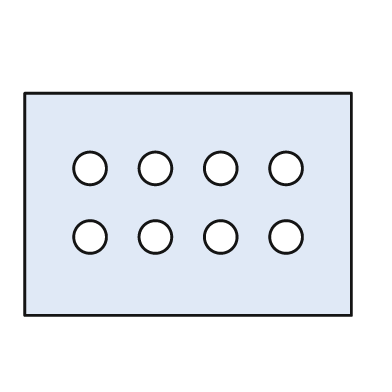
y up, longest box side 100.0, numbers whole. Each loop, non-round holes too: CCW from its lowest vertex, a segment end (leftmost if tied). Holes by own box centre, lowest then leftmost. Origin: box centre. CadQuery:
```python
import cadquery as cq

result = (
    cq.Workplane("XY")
    .moveTo(-50.0, -34.0)
    .lineTo(50.0, -34.0)
    .lineTo(50.0, 34.0)
    .lineTo(-50.0, 34.0)
    .close()
    .moveTo(-30.0, -10.0)
    .circle(5.0)
    .moveTo(-10.0, -10.0)
    .circle(5.0)
    .moveTo(10.0, -10.0)
    .circle(5.0)
    .moveTo(30.0, -10.0)
    .circle(5.0)
    .moveTo(-30.0, 11.0)
    .circle(5.0)
    .moveTo(-10.0, 11.0)
    .circle(5.0)
    .moveTo(10.0, 11.0)
    .circle(5.0)
    .moveTo(30.0, 11.0)
    .circle(5.0)
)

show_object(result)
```